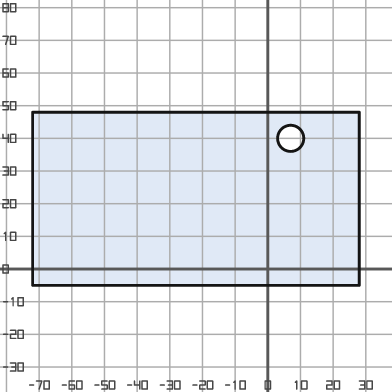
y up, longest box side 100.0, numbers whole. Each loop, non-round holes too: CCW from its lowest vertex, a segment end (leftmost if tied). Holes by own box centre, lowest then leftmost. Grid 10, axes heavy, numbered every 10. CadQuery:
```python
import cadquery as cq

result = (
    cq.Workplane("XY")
    .moveTo(-72.0, -5.0)
    .lineTo(28.0, -5.0)
    .lineTo(28.0, 48.0)
    .lineTo(-72.0, 48.0)
    .close()
    .moveTo(7.0, 40.0)
    .circle(4.0)
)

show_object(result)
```